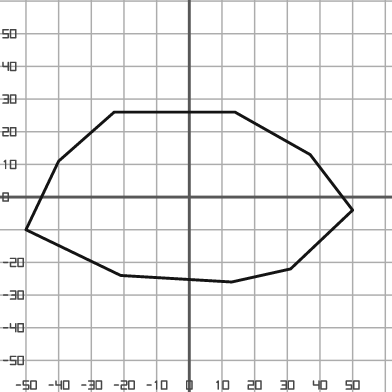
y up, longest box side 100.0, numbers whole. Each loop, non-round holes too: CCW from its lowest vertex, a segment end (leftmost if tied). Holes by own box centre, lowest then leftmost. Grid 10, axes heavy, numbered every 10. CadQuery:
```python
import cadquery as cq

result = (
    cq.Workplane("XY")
    .moveTo(13.0, -26.0)
    .lineTo(31.0, -22.0)
    .lineTo(50.0, -4.0)
    .lineTo(37.0, 13.0)
    .lineTo(14.0, 26.0)
    .lineTo(-23.0, 26.0)
    .lineTo(-40.0, 11.0)
    .lineTo(-50.0, -10.0)
    .lineTo(-21.0, -24.0)
    .close()
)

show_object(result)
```